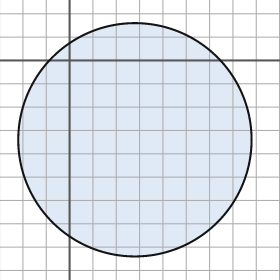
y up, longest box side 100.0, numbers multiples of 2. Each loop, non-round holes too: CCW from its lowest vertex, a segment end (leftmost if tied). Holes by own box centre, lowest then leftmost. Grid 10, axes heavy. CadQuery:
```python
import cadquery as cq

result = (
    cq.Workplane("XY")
    .moveTo(28.0, -34.0)
    .circle(50.0)
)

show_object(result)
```